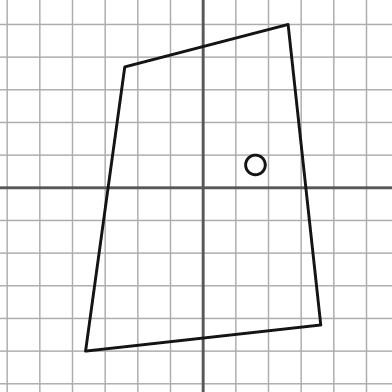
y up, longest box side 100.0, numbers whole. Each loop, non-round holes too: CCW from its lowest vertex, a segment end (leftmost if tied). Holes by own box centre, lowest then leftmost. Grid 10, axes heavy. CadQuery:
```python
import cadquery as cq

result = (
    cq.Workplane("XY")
    .moveTo(-36.0, -50.0)
    .lineTo(36.0, -42.0)
    .lineTo(26.0, 50.0)
    .lineTo(-24.0, 37.0)
    .close()
    .moveTo(16.0, 7.0)
    .circle(3.0)
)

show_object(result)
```